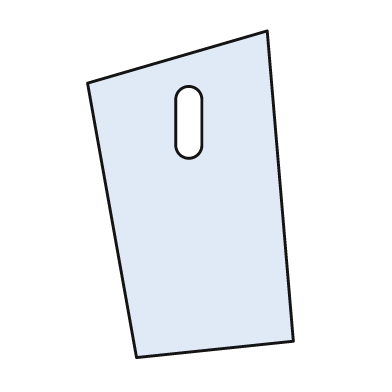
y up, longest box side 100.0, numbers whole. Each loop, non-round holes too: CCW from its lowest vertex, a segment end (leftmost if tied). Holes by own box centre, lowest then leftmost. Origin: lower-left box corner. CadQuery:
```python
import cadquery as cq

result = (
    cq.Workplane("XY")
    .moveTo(15.0, 0.0)
    .lineTo(63.0, 5.0)
    .lineTo(55.0, 100.0)
    .lineTo(0.0, 84.0)
    .close()
    .moveTo(27.0, 65.0)
    .threePointArc((31.0, 61.0), (35.0, 65.0))
    .lineTo(35.0, 79.0)
    .threePointArc((31.0, 83.0), (27.0, 79.0))
    .close()
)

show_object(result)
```